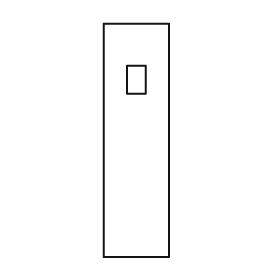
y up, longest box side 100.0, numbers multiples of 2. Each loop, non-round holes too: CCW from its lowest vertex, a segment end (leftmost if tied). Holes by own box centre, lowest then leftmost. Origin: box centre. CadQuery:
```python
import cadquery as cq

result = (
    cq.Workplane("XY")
    .moveTo(-14.0, -50.0)
    .lineTo(14.0, -50.0)
    .lineTo(14.0, 50.0)
    .lineTo(-14.0, 50.0)
    .close()
    .moveTo(-4.0, 20.0)
    .lineTo(4.0, 20.0)
    .lineTo(4.0, 32.0)
    .lineTo(-4.0, 32.0)
    .close()
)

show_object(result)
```